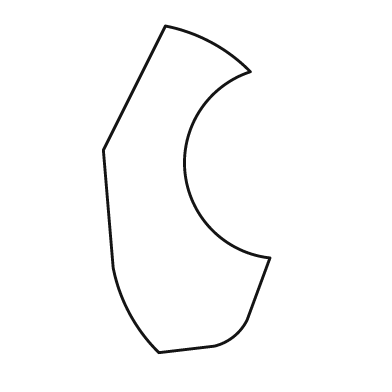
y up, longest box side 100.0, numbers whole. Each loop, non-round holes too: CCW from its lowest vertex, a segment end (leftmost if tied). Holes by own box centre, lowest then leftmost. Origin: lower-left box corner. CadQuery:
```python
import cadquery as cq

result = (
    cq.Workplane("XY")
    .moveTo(17.0, 0.0)
    .lineTo(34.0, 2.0)
    .threePointArc((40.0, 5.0), (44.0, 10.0))
    .lineTo(51.0, 29.0)
    .threePointArc((25.0, 55.0), (45.0, 86.0))
    .threePointArc((33.0, 95.0), (19.0, 100.0))
    .lineTo(0.0, 62.0)
    .lineTo(3.0, 26.0)
    .threePointArc((8.0, 12.0), (17.0, 0.0))
    .close()
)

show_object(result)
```